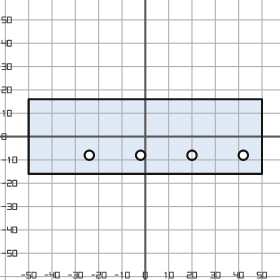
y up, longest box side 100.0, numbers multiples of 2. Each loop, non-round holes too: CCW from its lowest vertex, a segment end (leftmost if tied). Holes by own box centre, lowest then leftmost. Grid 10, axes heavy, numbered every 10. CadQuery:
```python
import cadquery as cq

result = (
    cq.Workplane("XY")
    .moveTo(-50.0, -16.0)
    .lineTo(50.0, -16.0)
    .lineTo(50.0, 16.0)
    .lineTo(-50.0, 16.0)
    .close()
    .moveTo(-24.0, -8.0)
    .circle(2.0)
    .moveTo(-2.0, -8.0)
    .circle(2.0)
    .moveTo(20.0, -8.0)
    .circle(2.0)
    .moveTo(42.0, -8.0)
    .circle(2.0)
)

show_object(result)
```